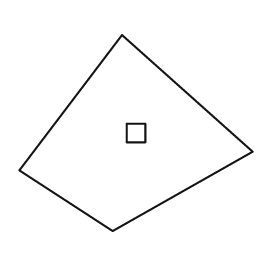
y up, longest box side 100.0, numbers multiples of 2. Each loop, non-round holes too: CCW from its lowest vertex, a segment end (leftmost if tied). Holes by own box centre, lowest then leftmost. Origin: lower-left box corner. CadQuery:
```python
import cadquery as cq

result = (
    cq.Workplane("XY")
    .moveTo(40.0, 0.0)
    .lineTo(100.0, 34.0)
    .lineTo(44.0, 84.0)
    .lineTo(0.0, 26.0)
    .close()
    .moveTo(46.0, 38.0)
    .lineTo(54.0, 38.0)
    .lineTo(54.0, 46.0)
    .lineTo(46.0, 46.0)
    .close()
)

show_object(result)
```